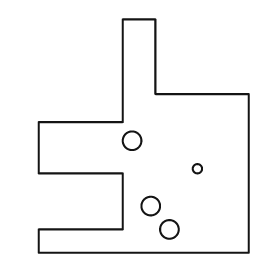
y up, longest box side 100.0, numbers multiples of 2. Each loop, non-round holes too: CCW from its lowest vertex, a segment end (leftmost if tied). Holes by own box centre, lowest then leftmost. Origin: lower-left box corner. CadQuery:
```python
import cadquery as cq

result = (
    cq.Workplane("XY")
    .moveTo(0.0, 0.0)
    .lineTo(90.0, 0.0)
    .lineTo(90.0, 68.0)
    .lineTo(50.0, 68.0)
    .lineTo(50.0, 100.0)
    .lineTo(36.0, 100.0)
    .lineTo(36.0, 56.0)
    .lineTo(0.0, 56.0)
    .lineTo(0.0, 34.0)
    .lineTo(36.0, 34.0)
    .lineTo(36.0, 10.0)
    .lineTo(0.0, 10.0)
    .close()
    .moveTo(56.0, 10.0)
    .circle(4.0)
    .moveTo(48.0, 20.0)
    .circle(4.0)
    .moveTo(68.0, 36.0)
    .circle(2.0)
    .moveTo(40.0, 48.0)
    .circle(4.0)
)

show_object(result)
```